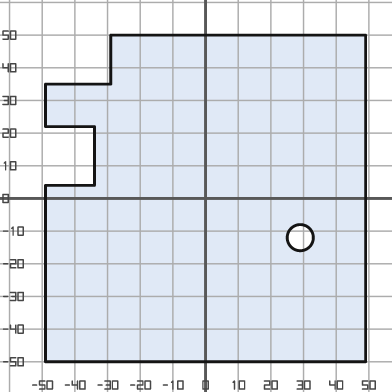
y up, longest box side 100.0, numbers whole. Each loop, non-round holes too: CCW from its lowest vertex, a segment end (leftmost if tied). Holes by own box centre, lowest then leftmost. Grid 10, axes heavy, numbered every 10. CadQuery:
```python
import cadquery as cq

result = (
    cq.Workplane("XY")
    .moveTo(-49.0, -50.0)
    .lineTo(49.0, -50.0)
    .lineTo(49.0, 50.0)
    .lineTo(-29.0, 50.0)
    .lineTo(-29.0, 35.0)
    .lineTo(-49.0, 35.0)
    .lineTo(-49.0, 22.0)
    .lineTo(-34.0, 22.0)
    .lineTo(-34.0, 4.0)
    .lineTo(-49.0, 4.0)
    .close()
    .moveTo(29.0, -12.0)
    .circle(4.0)
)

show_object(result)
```